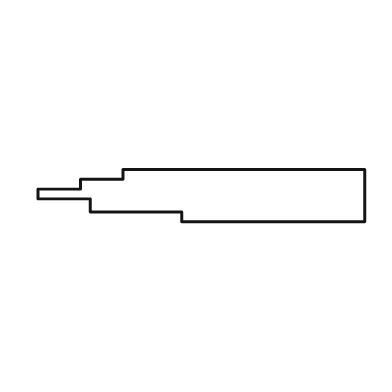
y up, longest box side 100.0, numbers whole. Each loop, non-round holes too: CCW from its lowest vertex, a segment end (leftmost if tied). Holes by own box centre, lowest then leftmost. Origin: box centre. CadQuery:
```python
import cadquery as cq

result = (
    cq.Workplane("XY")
    .moveTo(-6.0, -8.0)
    .lineTo(50.0, -8.0)
    .lineTo(50.0, 8.0)
    .lineTo(-24.0, 8.0)
    .lineTo(-24.0, 5.0)
    .lineTo(-37.0, 5.0)
    .lineTo(-37.0, 2.0)
    .lineTo(-50.0, 2.0)
    .lineTo(-50.0, -1.0)
    .lineTo(-34.0, -1.0)
    .lineTo(-34.0, -5.0)
    .lineTo(-6.0, -5.0)
    .close()
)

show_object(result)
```